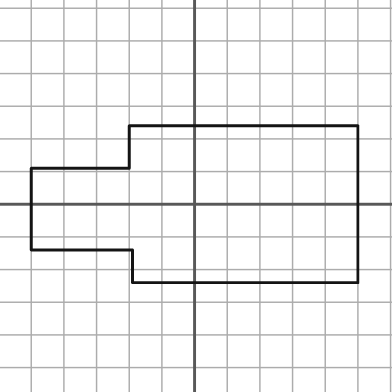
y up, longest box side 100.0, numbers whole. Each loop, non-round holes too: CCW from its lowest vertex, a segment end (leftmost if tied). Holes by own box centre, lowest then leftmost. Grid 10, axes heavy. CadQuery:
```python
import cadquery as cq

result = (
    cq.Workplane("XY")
    .moveTo(-19.0, -24.0)
    .lineTo(50.0, -24.0)
    .lineTo(50.0, 24.0)
    .lineTo(-20.0, 24.0)
    .lineTo(-20.0, 11.0)
    .lineTo(-50.0, 11.0)
    .lineTo(-50.0, -14.0)
    .lineTo(-19.0, -14.0)
    .close()
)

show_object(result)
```